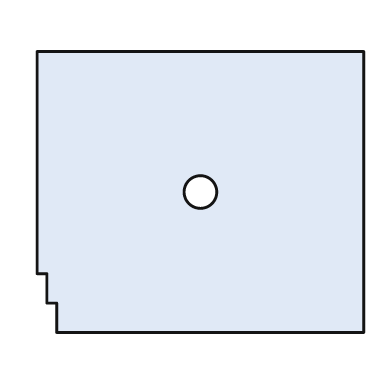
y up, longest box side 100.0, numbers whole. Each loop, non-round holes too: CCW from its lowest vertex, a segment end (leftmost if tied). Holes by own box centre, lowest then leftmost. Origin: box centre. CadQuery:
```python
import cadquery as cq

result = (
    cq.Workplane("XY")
    .moveTo(-44.0, -43.0)
    .lineTo(50.0, -43.0)
    .lineTo(50.0, 43.0)
    .lineTo(-50.0, 43.0)
    .lineTo(-50.0, -25.0)
    .lineTo(-47.0, -25.0)
    .lineTo(-47.0, -34.0)
    .lineTo(-44.0, -34.0)
    .close()
    .moveTo(0.0, 0.0)
    .circle(5.0)
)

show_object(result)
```